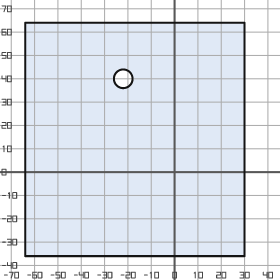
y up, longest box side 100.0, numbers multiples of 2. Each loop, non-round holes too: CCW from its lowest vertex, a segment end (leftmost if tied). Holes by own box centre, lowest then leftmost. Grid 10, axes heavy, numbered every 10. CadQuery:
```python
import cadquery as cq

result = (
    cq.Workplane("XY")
    .moveTo(-64.0, -36.0)
    .lineTo(30.0, -36.0)
    .lineTo(30.0, 64.0)
    .lineTo(-64.0, 64.0)
    .close()
    .moveTo(-22.0, 40.0)
    .circle(4.0)
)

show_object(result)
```